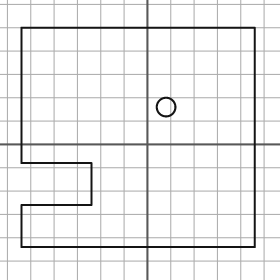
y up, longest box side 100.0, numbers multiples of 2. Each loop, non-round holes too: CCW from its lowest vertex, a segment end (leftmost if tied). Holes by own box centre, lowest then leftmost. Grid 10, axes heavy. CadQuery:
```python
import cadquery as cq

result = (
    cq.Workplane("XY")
    .moveTo(-54.0, -44.0)
    .lineTo(46.0, -44.0)
    .lineTo(46.0, 50.0)
    .lineTo(-54.0, 50.0)
    .lineTo(-54.0, -8.0)
    .lineTo(-24.0, -8.0)
    .lineTo(-24.0, -26.0)
    .lineTo(-54.0, -26.0)
    .close()
    .moveTo(8.0, 16.0)
    .circle(4.0)
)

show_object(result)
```